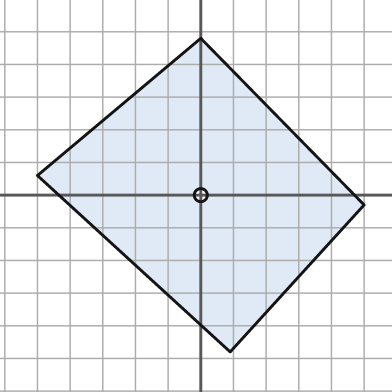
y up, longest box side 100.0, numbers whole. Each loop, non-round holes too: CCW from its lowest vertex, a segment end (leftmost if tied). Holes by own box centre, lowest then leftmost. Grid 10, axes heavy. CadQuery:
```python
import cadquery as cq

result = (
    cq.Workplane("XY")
    .moveTo(9.0, -48.0)
    .lineTo(50.0, -3.0)
    .lineTo(0.0, 48.0)
    .lineTo(-50.0, 6.0)
    .close()
    .moveTo(0.0, 0.0)
    .circle(2.0)
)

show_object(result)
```